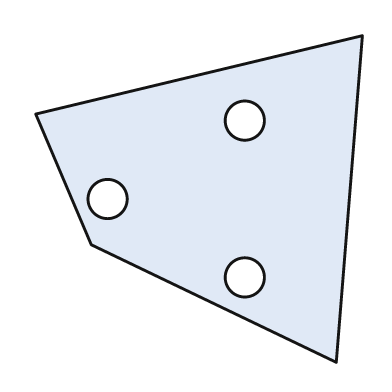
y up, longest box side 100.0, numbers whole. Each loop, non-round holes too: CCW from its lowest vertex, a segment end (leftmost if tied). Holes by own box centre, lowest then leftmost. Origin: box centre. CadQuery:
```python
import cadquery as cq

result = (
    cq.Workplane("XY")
    .moveTo(42.0, -50.0)
    .lineTo(50.0, 50.0)
    .lineTo(-50.0, 26.0)
    .lineTo(-33.0, -14.0)
    .close()
    .moveTo(14.0, -24.0)
    .circle(6.0)
    .moveTo(-28.0, 0.0)
    .circle(6.0)
    .moveTo(14.0, 24.0)
    .circle(6.0)
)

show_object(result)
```